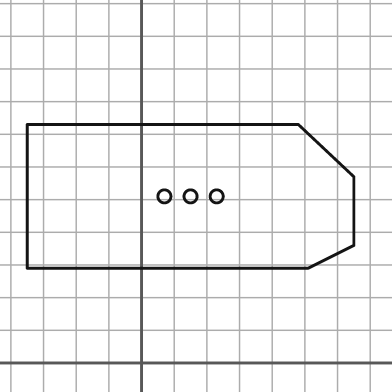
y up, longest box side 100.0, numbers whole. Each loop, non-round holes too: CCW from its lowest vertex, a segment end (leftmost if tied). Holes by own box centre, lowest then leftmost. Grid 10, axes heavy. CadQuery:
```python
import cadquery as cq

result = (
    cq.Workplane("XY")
    .moveTo(-35.0, 29.0)
    .lineTo(51.0, 29.0)
    .lineTo(65.0, 36.0)
    .lineTo(65.0, 57.0)
    .lineTo(48.0, 73.0)
    .lineTo(-35.0, 73.0)
    .close()
    .moveTo(7.0, 51.0)
    .circle(2.0)
    .moveTo(15.0, 51.0)
    .circle(2.0)
    .moveTo(23.0, 51.0)
    .circle(2.0)
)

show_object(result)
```